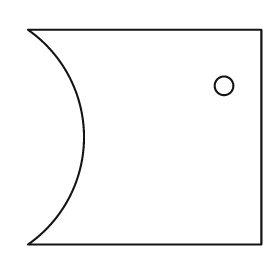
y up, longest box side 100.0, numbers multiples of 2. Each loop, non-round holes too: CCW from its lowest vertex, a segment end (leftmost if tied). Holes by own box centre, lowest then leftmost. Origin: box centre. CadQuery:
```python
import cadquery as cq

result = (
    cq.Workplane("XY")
    .moveTo(-50.0, -46.0)
    .lineTo(50.0, -46.0)
    .lineTo(50.0, 46.0)
    .lineTo(-50.0, 46.0)
    .threePointArc((-26.0, 0.0), (-50.0, -46.0))
    .close()
    .moveTo(34.0, 22.0)
    .circle(4.0)
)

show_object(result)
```